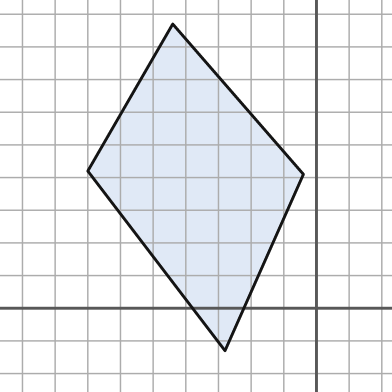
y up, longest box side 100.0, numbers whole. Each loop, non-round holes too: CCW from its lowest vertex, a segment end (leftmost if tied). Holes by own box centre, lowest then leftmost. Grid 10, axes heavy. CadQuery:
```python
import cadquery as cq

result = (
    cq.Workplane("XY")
    .moveTo(-28.0, -13.0)
    .lineTo(-4.0, 41.0)
    .lineTo(-44.0, 87.0)
    .lineTo(-70.0, 42.0)
    .close()
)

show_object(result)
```